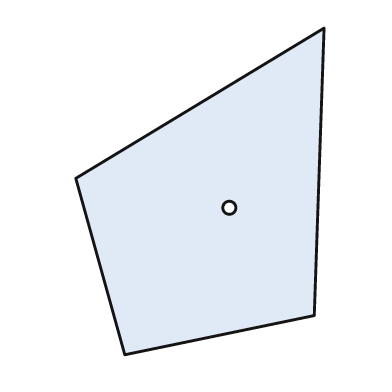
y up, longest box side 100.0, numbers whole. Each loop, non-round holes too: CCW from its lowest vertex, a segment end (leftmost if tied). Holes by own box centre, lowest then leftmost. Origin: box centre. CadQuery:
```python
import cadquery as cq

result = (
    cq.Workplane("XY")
    .moveTo(-23.0, -50.0)
    .lineTo(35.0, -38.0)
    .lineTo(38.0, 50.0)
    .lineTo(-38.0, 4.0)
    .close()
    .moveTo(9.0, -5.0)
    .circle(2.0)
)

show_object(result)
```